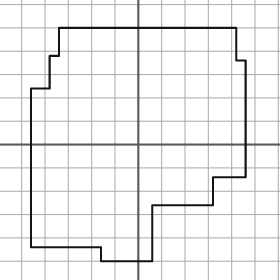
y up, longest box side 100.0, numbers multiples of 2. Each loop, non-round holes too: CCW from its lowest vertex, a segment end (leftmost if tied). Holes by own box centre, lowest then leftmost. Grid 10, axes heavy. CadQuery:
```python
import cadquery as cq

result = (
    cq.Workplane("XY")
    .moveTo(-16.0, -50.0)
    .lineTo(6.0, -50.0)
    .lineTo(6.0, -26.0)
    .lineTo(32.0, -26.0)
    .lineTo(32.0, -14.0)
    .lineTo(46.0, -14.0)
    .lineTo(46.0, 36.0)
    .lineTo(42.0, 36.0)
    .lineTo(42.0, 50.0)
    .lineTo(-34.0, 50.0)
    .lineTo(-34.0, 38.0)
    .lineTo(-38.0, 38.0)
    .lineTo(-38.0, 24.0)
    .lineTo(-46.0, 24.0)
    .lineTo(-46.0, -44.0)
    .lineTo(-16.0, -44.0)
    .close()
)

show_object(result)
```